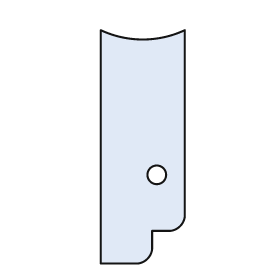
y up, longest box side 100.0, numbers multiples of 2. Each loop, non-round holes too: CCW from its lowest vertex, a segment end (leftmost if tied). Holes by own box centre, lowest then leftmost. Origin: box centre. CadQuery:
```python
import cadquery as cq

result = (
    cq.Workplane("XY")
    .moveTo(-18.0, -50.0)
    .lineTo(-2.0, -50.0)
    .threePointArc((2.0, -48.0), (4.0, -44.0))
    .lineTo(4.0, -36.0)
    .lineTo(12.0, -36.0)
    .threePointArc((16.0, -34.0), (18.0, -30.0))
    .lineTo(18.0, 50.0)
    .threePointArc((0.0, 46.0), (-18.0, 50.0))
    .close()
    .moveTo(6.0, -12.0)
    .circle(4.0)
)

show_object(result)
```